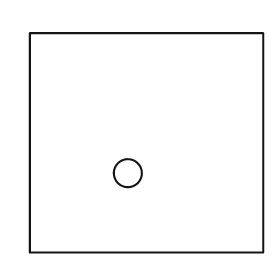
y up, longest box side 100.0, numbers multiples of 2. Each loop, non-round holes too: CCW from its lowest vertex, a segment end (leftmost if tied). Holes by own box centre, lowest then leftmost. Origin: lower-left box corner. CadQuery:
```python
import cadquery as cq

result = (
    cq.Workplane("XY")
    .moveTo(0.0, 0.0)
    .lineTo(100.0, 0.0)
    .lineTo(100.0, 94.0)
    .lineTo(0.0, 94.0)
    .close()
    .moveTo(42.0, 34.0)
    .circle(6.0)
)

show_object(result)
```